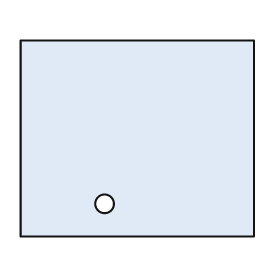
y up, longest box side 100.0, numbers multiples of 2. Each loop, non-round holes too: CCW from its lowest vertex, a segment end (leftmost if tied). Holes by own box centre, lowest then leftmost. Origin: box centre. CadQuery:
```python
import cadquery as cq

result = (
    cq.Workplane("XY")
    .moveTo(-50.0, -42.0)
    .lineTo(50.0, -42.0)
    .lineTo(50.0, 42.0)
    .lineTo(-50.0, 42.0)
    .close()
    .moveTo(-14.0, -28.0)
    .circle(4.0)
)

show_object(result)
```